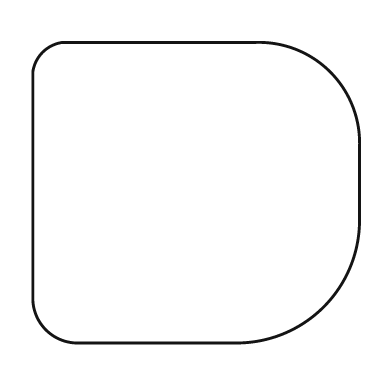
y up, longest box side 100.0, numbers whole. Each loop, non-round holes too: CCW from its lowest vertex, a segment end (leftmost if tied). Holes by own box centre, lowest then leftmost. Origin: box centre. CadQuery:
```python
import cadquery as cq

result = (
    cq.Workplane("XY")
    .moveTo(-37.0, -46.0)
    .lineTo(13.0, -46.0)
    .threePointArc((39.0, -35.0), (50.0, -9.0))
    .lineTo(50.0, 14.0)
    .threePointArc((41.0, 37.0), (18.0, 46.0))
    .lineTo(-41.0, 46.0)
    .threePointArc((-47.0, 43.0), (-50.0, 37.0))
    .lineTo(-50.0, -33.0)
    .threePointArc((-46.0, -42.0), (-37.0, -46.0))
    .close()
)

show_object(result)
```